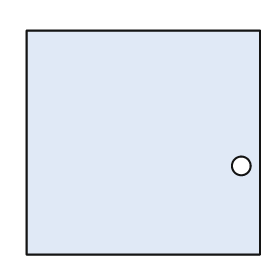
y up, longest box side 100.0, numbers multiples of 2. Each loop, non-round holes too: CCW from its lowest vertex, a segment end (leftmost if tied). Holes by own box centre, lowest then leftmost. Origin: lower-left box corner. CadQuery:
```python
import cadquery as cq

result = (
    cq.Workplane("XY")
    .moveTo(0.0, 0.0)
    .lineTo(100.0, 0.0)
    .lineTo(100.0, 96.0)
    .lineTo(0.0, 96.0)
    .close()
    .moveTo(92.0, 38.0)
    .circle(4.0)
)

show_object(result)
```